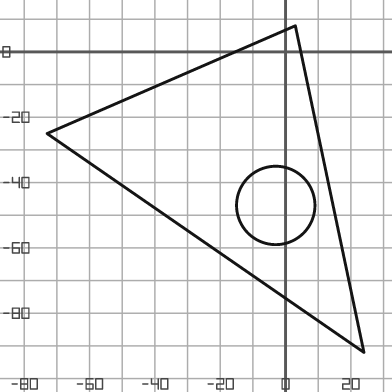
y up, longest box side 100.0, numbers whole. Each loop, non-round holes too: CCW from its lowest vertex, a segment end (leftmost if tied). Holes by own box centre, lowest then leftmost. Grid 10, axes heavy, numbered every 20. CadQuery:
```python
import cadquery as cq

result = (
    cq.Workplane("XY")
    .moveTo(24.0, -92.0)
    .lineTo(3.0, 8.0)
    .lineTo(-73.0, -25.0)
    .close()
    .moveTo(-3.0, -47.0)
    .circle(12.0)
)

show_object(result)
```